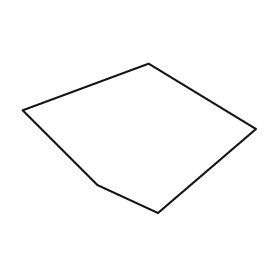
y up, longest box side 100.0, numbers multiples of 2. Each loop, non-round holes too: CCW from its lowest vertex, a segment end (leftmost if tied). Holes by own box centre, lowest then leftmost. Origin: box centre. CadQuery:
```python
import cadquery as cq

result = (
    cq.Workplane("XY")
    .moveTo(8.0, -32.0)
    .lineTo(50.0, 4.0)
    .lineTo(4.0, 32.0)
    .lineTo(-50.0, 12.0)
    .lineTo(-18.0, -20.0)
    .close()
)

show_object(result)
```